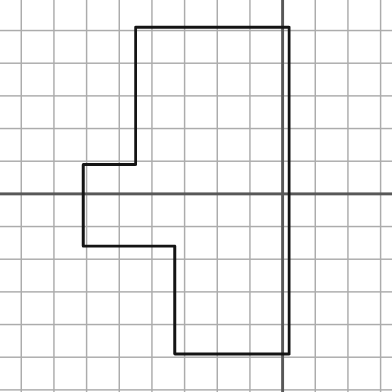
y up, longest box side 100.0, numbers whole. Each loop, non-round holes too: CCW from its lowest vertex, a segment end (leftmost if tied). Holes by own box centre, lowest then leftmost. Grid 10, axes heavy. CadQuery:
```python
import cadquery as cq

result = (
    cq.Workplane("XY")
    .moveTo(-33.0, -49.0)
    .lineTo(2.0, -49.0)
    .lineTo(2.0, 51.0)
    .lineTo(-45.0, 51.0)
    .lineTo(-45.0, 9.0)
    .lineTo(-61.0, 9.0)
    .lineTo(-61.0, -16.0)
    .lineTo(-33.0, -16.0)
    .close()
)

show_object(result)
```